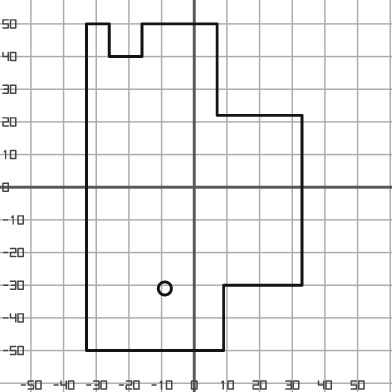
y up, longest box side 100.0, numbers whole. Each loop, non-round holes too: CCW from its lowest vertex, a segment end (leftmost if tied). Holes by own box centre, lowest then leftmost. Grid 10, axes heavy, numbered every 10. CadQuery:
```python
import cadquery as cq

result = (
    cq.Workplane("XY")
    .moveTo(-33.0, -50.0)
    .lineTo(9.0, -50.0)
    .lineTo(9.0, -30.0)
    .lineTo(33.0, -30.0)
    .lineTo(33.0, 22.0)
    .lineTo(7.0, 22.0)
    .lineTo(7.0, 50.0)
    .lineTo(-16.0, 50.0)
    .lineTo(-16.0, 40.0)
    .lineTo(-26.0, 40.0)
    .lineTo(-26.0, 50.0)
    .lineTo(-33.0, 50.0)
    .close()
    .moveTo(-9.0, -31.0)
    .circle(2.0)
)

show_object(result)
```